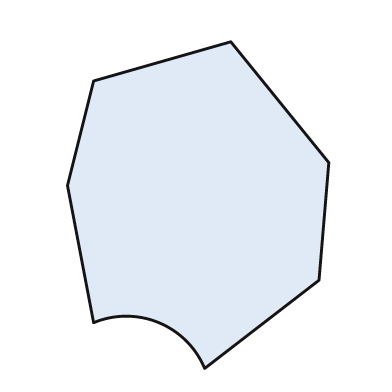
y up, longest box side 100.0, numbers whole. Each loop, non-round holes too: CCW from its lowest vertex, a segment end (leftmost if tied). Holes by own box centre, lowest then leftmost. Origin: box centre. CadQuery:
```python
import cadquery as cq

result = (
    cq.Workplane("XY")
    .moveTo(2.0, -50.0)
    .lineTo(37.0, -23.0)
    .lineTo(40.0, 13.0)
    .lineTo(10.0, 50.0)
    .lineTo(-32.0, 38.0)
    .lineTo(-40.0, 6.0)
    .lineTo(-32.0, -36.0)
    .threePointArc((-12.0, -36.0), (2.0, -50.0))
    .close()
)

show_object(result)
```